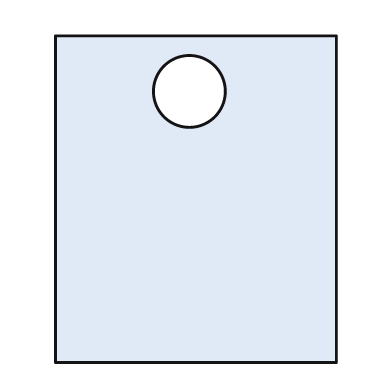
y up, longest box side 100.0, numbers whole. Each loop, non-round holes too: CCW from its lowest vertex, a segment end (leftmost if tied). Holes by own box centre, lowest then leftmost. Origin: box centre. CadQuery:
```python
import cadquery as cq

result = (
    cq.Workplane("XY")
    .moveTo(-43.0, -50.0)
    .lineTo(43.0, -50.0)
    .lineTo(43.0, 50.0)
    .lineTo(-43.0, 50.0)
    .close()
    .moveTo(-2.0, 33.0)
    .circle(11.0)
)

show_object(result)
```